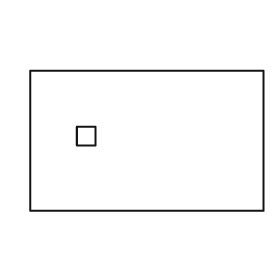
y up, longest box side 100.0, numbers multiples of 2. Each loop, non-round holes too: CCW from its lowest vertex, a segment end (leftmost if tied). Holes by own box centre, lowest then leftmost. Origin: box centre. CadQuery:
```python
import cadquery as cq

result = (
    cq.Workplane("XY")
    .moveTo(-50.0, -30.0)
    .lineTo(50.0, -30.0)
    .lineTo(50.0, 30.0)
    .lineTo(-50.0, 30.0)
    .close()
    .moveTo(-30.0, -2.0)
    .lineTo(-22.0, -2.0)
    .lineTo(-22.0, 6.0)
    .lineTo(-30.0, 6.0)
    .close()
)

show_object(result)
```